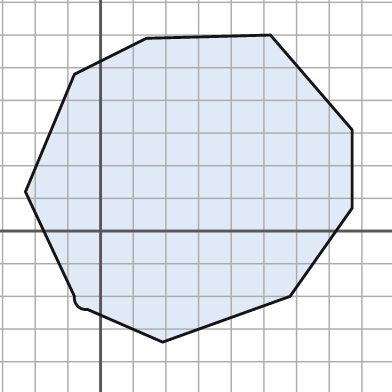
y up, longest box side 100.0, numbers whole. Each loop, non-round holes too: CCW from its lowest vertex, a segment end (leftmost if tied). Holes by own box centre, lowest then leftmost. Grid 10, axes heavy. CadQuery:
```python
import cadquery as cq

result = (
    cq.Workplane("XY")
    .moveTo(19.0, -34.0)
    .lineTo(58.0, -20.0)
    .lineTo(77.0, 7.0)
    .lineTo(77.0, 31.0)
    .lineTo(52.0, 60.0)
    .lineTo(14.0, 59.0)
    .lineTo(-8.0, 48.0)
    .lineTo(-23.0, 12.0)
    .lineTo(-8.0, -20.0)
    .threePointArc((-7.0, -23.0), (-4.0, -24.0))
    .close()
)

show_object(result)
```